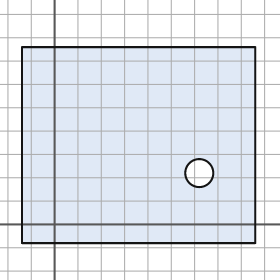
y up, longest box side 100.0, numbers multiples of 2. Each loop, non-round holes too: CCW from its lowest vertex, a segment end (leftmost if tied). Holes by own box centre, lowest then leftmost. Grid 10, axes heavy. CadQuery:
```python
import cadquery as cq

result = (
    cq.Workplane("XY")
    .moveTo(-14.0, -8.0)
    .lineTo(86.0, -8.0)
    .lineTo(86.0, 76.0)
    .lineTo(-14.0, 76.0)
    .close()
    .moveTo(62.0, 22.0)
    .circle(6.0)
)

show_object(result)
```